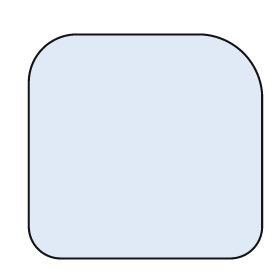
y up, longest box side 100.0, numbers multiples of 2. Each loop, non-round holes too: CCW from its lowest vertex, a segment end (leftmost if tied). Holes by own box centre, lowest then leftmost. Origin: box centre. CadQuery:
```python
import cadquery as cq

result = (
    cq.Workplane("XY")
    .moveTo(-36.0, -48.0)
    .lineTo(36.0, -48.0)
    .threePointArc((46.0, -44.0), (50.0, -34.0))
    .lineTo(50.0, 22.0)
    .threePointArc((42.0, 40.0), (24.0, 48.0))
    .lineTo(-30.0, 48.0)
    .threePointArc((-44.0, 42.0), (-50.0, 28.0))
    .lineTo(-50.0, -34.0)
    .threePointArc((-46.0, -44.0), (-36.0, -48.0))
    .close()
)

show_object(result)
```